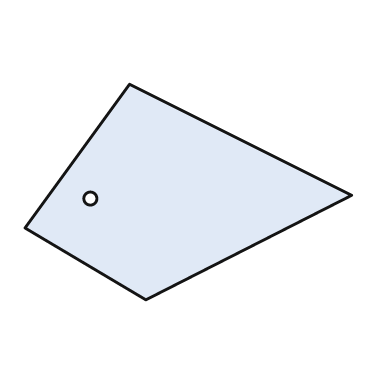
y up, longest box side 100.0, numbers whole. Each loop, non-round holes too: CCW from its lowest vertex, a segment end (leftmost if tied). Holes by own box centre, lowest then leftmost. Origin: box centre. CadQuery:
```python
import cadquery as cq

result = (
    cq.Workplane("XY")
    .moveTo(-13.0, -33.0)
    .lineTo(50.0, -1.0)
    .lineTo(-18.0, 33.0)
    .lineTo(-50.0, -11.0)
    .close()
    .moveTo(-30.0, -2.0)
    .circle(2.0)
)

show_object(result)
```